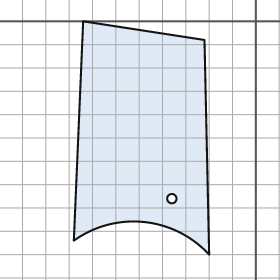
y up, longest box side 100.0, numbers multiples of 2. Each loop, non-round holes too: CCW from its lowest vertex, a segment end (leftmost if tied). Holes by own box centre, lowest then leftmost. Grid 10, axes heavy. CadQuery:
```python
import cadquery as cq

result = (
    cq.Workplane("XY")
    .moveTo(-20.0, -100.0)
    .lineTo(-22.0, -8.0)
    .lineTo(-74.0, 0.0)
    .lineTo(-78.0, -94.0)
    .threePointArc((-48.0, -86.0), (-20.0, -100.0))
    .close()
    .moveTo(-36.0, -76.0)
    .circle(2.0)
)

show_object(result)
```